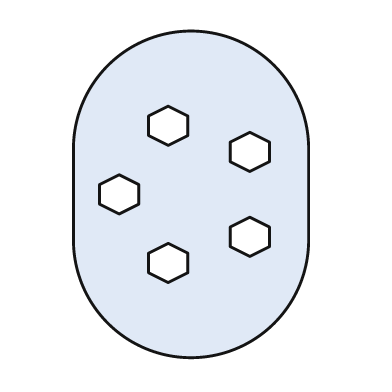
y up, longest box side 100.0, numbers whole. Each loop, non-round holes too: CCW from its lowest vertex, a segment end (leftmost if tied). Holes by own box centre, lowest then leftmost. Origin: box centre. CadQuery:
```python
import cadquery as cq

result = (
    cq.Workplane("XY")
    .moveTo(-36.0, -14.0)
    .threePointArc((0.0, -50.0), (36.0, -14.0))
    .lineTo(36.0, 14.0)
    .threePointArc((0.0, 50.0), (-36.0, 14.0))
    .close()
    .moveTo(-7.0, -27.0)
    .lineTo(-1.0, -24.0)
    .lineTo(-1.0, -18.0)
    .lineTo(-7.0, -15.0)
    .lineTo(-13.0, -18.0)
    .lineTo(-13.0, -24.0)
    .close()
    .moveTo(18.0, -19.0)
    .lineTo(24.0, -16.0)
    .lineTo(24.0, -10.0)
    .lineTo(18.0, -7.0)
    .lineTo(12.0, -10.0)
    .lineTo(12.0, -16.0)
    .close()
    .moveTo(-22.0, -6.0)
    .lineTo(-16.0, -3.0)
    .lineTo(-16.0, 3.0)
    .lineTo(-22.0, 6.0)
    .lineTo(-28.0, 3.0)
    .lineTo(-28.0, -3.0)
    .close()
    .moveTo(18.0, 7.0)
    .lineTo(24.0, 10.0)
    .lineTo(24.0, 16.0)
    .lineTo(18.0, 19.0)
    .lineTo(12.0, 16.0)
    .lineTo(12.0, 10.0)
    .close()
    .moveTo(-7.0, 15.0)
    .lineTo(-1.0, 18.0)
    .lineTo(-1.0, 24.0)
    .lineTo(-7.0, 27.0)
    .lineTo(-13.0, 24.0)
    .lineTo(-13.0, 18.0)
    .close()
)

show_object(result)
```